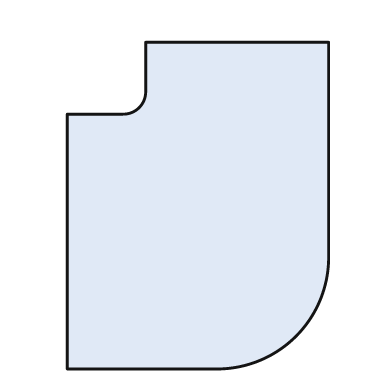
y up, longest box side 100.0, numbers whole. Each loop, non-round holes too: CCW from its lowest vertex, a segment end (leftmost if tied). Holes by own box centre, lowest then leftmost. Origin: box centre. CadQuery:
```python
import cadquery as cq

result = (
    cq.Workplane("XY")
    .moveTo(-40.0, -50.0)
    .lineTo(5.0, -50.0)
    .threePointArc((30.0, -40.0), (40.0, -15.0))
    .lineTo(40.0, 50.0)
    .lineTo(-16.0, 50.0)
    .lineTo(-16.0, 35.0)
    .threePointArc((-18.0, 30.0), (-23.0, 28.0))
    .lineTo(-40.0, 28.0)
    .close()
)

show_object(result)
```